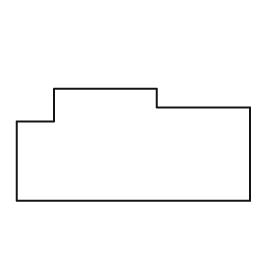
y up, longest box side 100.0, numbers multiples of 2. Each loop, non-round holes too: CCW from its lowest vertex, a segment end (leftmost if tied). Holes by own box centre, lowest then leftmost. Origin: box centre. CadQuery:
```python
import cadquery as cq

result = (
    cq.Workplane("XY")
    .moveTo(-50.0, -24.0)
    .lineTo(50.0, -24.0)
    .lineTo(50.0, 16.0)
    .lineTo(10.0, 16.0)
    .lineTo(10.0, 24.0)
    .lineTo(-34.0, 24.0)
    .lineTo(-34.0, 10.0)
    .lineTo(-50.0, 10.0)
    .close()
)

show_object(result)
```